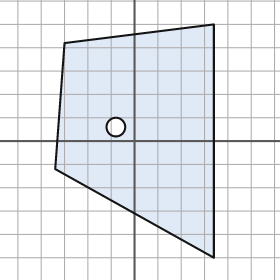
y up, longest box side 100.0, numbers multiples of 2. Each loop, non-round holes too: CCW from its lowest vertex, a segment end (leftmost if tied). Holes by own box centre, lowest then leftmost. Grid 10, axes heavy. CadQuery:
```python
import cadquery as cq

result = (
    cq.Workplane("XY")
    .moveTo(34.0, -50.0)
    .lineTo(34.0, 50.0)
    .lineTo(-30.0, 42.0)
    .lineTo(-34.0, -12.0)
    .close()
    .moveTo(-8.0, 6.0)
    .circle(4.0)
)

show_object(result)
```